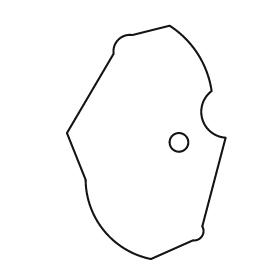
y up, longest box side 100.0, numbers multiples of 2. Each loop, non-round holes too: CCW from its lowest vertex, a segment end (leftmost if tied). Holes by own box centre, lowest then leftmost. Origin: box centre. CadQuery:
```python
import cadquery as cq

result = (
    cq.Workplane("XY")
    .moveTo(2.0, -50.0)
    .lineTo(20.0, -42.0)
    .threePointArc((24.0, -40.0), (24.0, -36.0))
    .lineTo(34.0, 2.0)
    .threePointArc((24.0, 10.0), (28.0, 22.0))
    .threePointArc((22.0, 38.0), (10.0, 50.0))
    .lineTo(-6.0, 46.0)
    .threePointArc((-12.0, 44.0), (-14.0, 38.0))
    .lineTo(-34.0, 4.0)
    .lineTo(-26.0, -16.0)
    .threePointArc((-18.0, -38.0), (2.0, -50.0))
    .close()
    .moveTo(14.0, 0.0)
    .circle(4.0)
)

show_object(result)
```